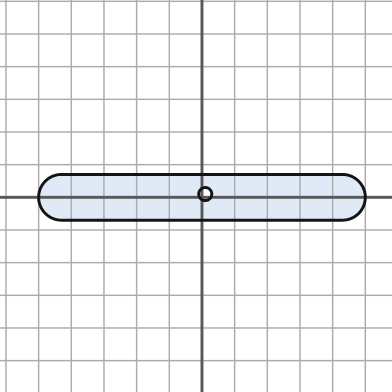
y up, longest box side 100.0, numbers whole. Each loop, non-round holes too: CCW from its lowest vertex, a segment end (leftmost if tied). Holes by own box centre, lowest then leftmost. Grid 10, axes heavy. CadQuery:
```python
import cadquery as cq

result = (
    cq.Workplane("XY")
    .moveTo(-43.0, -7.0)
    .lineTo(43.0, -7.0)
    .threePointArc((50.0, 0.0), (43.0, 7.0))
    .lineTo(-43.0, 7.0)
    .threePointArc((-50.0, 0.0), (-43.0, -7.0))
    .close()
    .moveTo(1.0, 1.0)
    .circle(2.0)
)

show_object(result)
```